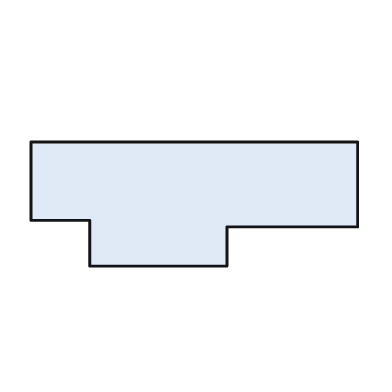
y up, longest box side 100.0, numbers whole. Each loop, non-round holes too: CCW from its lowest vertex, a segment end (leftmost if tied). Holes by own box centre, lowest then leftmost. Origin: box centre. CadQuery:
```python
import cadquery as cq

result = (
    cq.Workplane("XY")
    .moveTo(-32.0, -19.0)
    .lineTo(10.0, -19.0)
    .lineTo(10.0, -7.0)
    .lineTo(50.0, -7.0)
    .lineTo(50.0, 19.0)
    .lineTo(-50.0, 19.0)
    .lineTo(-50.0, -5.0)
    .lineTo(-32.0, -5.0)
    .close()
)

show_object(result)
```